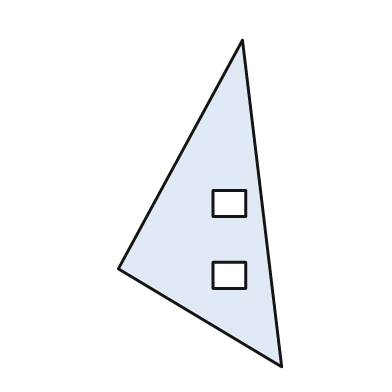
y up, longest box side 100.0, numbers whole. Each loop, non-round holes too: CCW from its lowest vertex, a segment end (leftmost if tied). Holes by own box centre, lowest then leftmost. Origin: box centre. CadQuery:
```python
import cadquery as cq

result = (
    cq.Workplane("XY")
    .moveTo(25.0, -50.0)
    .lineTo(13.0, 50.0)
    .lineTo(-25.0, -20.0)
    .close()
    .moveTo(4.0, -26.0)
    .lineTo(14.0, -26.0)
    .lineTo(14.0, -18.0)
    .lineTo(4.0, -18.0)
    .close()
    .moveTo(4.0, -4.0)
    .lineTo(14.0, -4.0)
    .lineTo(14.0, 4.0)
    .lineTo(4.0, 4.0)
    .close()
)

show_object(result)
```